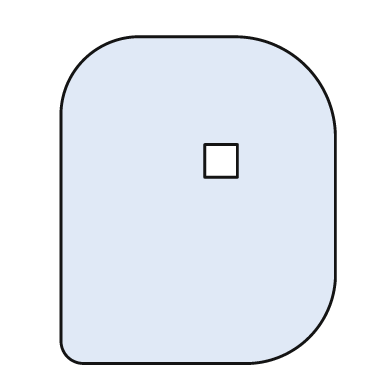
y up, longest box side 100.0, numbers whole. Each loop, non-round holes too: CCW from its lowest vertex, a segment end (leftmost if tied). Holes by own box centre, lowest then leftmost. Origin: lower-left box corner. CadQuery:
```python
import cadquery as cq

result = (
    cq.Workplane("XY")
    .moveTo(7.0, 0.0)
    .lineTo(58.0, 0.0)
    .threePointArc((76.0, 8.0), (84.0, 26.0))
    .lineTo(84.0, 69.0)
    .threePointArc((75.0, 91.0), (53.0, 100.0))
    .lineTo(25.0, 100.0)
    .threePointArc((7.0, 93.0), (0.0, 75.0))
    .lineTo(0.0, 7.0)
    .threePointArc((2.0, 2.0), (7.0, 0.0))
    .close()
    .moveTo(44.0, 57.0)
    .lineTo(54.0, 57.0)
    .lineTo(54.0, 67.0)
    .lineTo(44.0, 67.0)
    .close()
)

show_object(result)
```